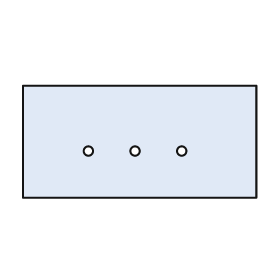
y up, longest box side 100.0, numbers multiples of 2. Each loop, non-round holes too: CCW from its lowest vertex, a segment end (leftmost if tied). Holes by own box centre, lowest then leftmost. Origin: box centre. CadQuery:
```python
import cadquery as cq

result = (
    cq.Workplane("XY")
    .moveTo(-50.0, -24.0)
    .lineTo(50.0, -24.0)
    .lineTo(50.0, 24.0)
    .lineTo(-50.0, 24.0)
    .close()
    .moveTo(-22.0, -4.0)
    .circle(2.0)
    .moveTo(-2.0, -4.0)
    .circle(2.0)
    .moveTo(18.0, -4.0)
    .circle(2.0)
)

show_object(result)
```